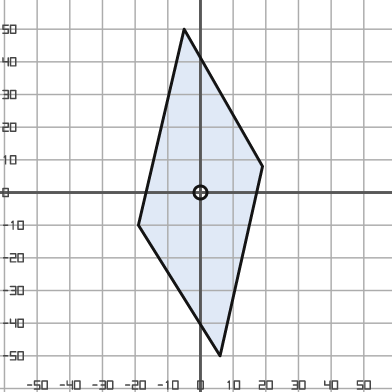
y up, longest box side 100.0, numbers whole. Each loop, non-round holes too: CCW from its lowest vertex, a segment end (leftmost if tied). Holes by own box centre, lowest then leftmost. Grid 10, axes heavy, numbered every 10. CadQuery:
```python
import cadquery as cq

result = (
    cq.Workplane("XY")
    .moveTo(6.0, -50.0)
    .lineTo(19.0, 8.0)
    .lineTo(-5.0, 50.0)
    .lineTo(-19.0, -10.0)
    .close()
    .moveTo(0.0, 0.0)
    .circle(2.0)
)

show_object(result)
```